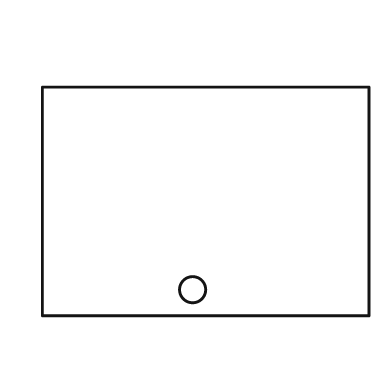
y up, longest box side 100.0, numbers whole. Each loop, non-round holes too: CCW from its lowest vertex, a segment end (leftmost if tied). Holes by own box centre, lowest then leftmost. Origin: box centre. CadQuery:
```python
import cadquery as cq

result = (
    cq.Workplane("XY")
    .moveTo(-50.0, -35.0)
    .lineTo(50.0, -35.0)
    .lineTo(50.0, 35.0)
    .lineTo(-50.0, 35.0)
    .close()
    .moveTo(-4.0, -27.0)
    .circle(4.0)
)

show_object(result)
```